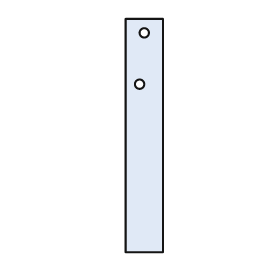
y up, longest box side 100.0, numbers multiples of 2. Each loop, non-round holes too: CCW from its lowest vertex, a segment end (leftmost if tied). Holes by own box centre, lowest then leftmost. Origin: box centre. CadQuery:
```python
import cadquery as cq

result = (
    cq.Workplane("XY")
    .moveTo(-8.0, -50.0)
    .lineTo(8.0, -50.0)
    .lineTo(8.0, 50.0)
    .lineTo(-8.0, 50.0)
    .close()
    .moveTo(-2.0, 22.0)
    .circle(2.0)
    .moveTo(0.0, 44.0)
    .circle(2.0)
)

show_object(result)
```